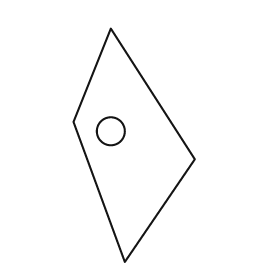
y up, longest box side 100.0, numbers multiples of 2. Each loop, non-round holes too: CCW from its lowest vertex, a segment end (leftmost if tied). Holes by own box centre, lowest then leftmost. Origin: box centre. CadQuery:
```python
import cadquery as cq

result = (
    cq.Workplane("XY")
    .moveTo(-4.0, -50.0)
    .lineTo(26.0, -6.0)
    .lineTo(-10.0, 50.0)
    .lineTo(-26.0, 10.0)
    .close()
    .moveTo(-10.0, 6.0)
    .circle(6.0)
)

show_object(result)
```